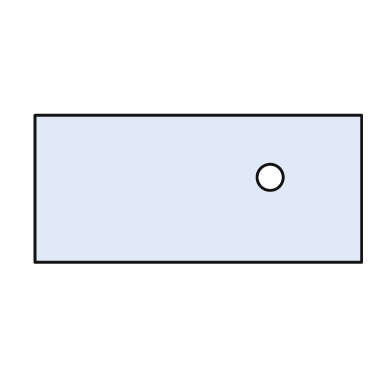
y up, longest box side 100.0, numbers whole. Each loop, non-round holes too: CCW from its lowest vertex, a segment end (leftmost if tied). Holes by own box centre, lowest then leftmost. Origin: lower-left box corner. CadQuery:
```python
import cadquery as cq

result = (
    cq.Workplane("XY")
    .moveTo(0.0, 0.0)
    .lineTo(100.0, 0.0)
    .lineTo(100.0, 45.0)
    .lineTo(0.0, 45.0)
    .close()
    .moveTo(72.0, 26.0)
    .circle(4.0)
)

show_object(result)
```